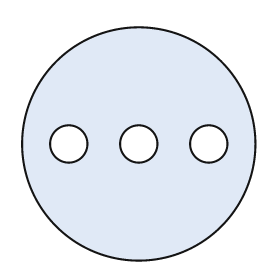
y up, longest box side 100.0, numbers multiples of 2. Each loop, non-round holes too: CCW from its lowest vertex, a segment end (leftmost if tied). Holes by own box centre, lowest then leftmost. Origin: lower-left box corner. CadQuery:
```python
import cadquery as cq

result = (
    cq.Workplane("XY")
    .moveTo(50.0, 50.0)
    .circle(50.0)
    .moveTo(20.0, 50.0)
    .circle(8.0)
    .moveTo(50.0, 50.0)
    .circle(8.0)
    .moveTo(80.0, 50.0)
    .circle(8.0)
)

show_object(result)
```